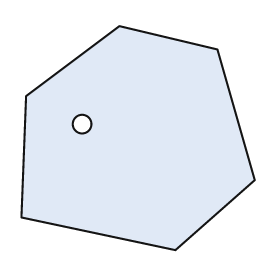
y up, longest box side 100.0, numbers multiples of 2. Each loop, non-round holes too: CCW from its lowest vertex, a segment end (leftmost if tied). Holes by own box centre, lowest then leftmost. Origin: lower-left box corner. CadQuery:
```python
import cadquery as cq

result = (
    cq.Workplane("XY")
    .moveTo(66.0, 0.0)
    .lineTo(100.0, 30.0)
    .lineTo(84.0, 86.0)
    .lineTo(42.0, 96.0)
    .lineTo(2.0, 66.0)
    .lineTo(0.0, 14.0)
    .close()
    .moveTo(26.0, 54.0)
    .circle(4.0)
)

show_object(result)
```